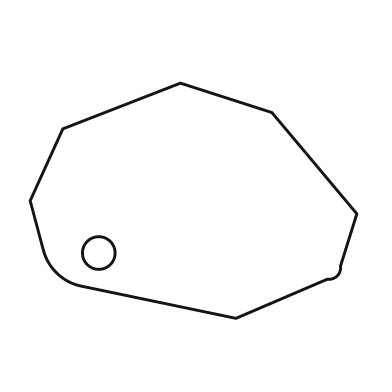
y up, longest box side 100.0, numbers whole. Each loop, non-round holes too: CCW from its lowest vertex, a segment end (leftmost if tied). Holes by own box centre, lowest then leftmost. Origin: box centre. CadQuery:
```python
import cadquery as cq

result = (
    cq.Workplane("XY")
    .moveTo(13.0, -36.0)
    .lineTo(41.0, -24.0)
    .threePointArc((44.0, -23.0), (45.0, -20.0))
    .lineTo(50.0, -4.0)
    .lineTo(24.0, 27.0)
    .lineTo(-4.0, 36.0)
    .lineTo(-40.0, 22.0)
    .lineTo(-50.0, 0.0)
    .lineTo(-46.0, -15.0)
    .threePointArc((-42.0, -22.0), (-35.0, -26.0))
    .close()
    .moveTo(-29.0, -16.0)
    .circle(5.0)
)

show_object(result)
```